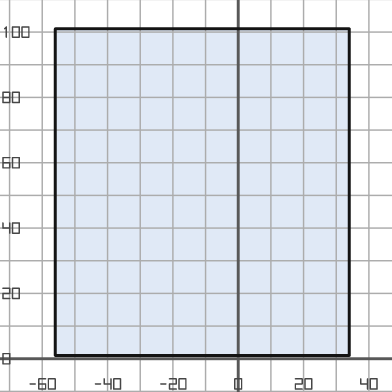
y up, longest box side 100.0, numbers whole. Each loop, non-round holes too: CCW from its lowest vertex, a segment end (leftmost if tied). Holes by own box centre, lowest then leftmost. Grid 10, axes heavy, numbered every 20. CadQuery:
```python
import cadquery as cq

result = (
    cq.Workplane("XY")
    .moveTo(-56.0, 1.0)
    .lineTo(34.0, 1.0)
    .lineTo(34.0, 101.0)
    .lineTo(-56.0, 101.0)
    .close()
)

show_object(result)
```